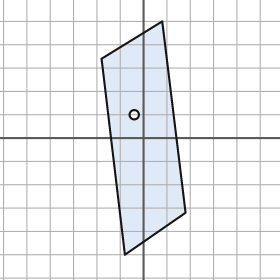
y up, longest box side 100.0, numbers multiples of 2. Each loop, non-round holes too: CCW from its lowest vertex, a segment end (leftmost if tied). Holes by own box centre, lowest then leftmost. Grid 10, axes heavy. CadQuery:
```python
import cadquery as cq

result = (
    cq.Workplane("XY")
    .moveTo(-8.0, -50.0)
    .lineTo(18.0, -32.0)
    .lineTo(8.0, 50.0)
    .lineTo(-18.0, 34.0)
    .close()
    .moveTo(-4.0, 10.0)
    .circle(2.0)
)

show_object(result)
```